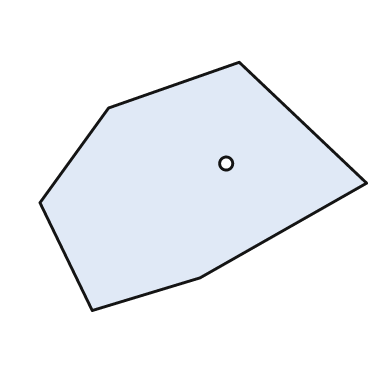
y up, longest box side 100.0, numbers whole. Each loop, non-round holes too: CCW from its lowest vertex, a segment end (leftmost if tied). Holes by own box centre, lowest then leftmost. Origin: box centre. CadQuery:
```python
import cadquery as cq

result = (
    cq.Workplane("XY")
    .moveTo(-34.0, -38.0)
    .lineTo(-1.0, -28.0)
    .lineTo(50.0, 1.0)
    .lineTo(11.0, 38.0)
    .lineTo(-29.0, 24.0)
    .lineTo(-50.0, -5.0)
    .close()
    .moveTo(7.0, 7.0)
    .circle(2.0)
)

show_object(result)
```